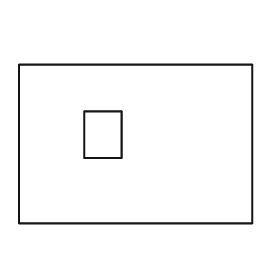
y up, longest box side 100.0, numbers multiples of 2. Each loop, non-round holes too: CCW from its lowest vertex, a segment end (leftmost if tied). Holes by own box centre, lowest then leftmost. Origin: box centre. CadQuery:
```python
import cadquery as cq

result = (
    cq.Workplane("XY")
    .moveTo(-50.0, -34.0)
    .lineTo(50.0, -34.0)
    .lineTo(50.0, 34.0)
    .lineTo(-50.0, 34.0)
    .close()
    .moveTo(-22.0, -6.0)
    .lineTo(-6.0, -6.0)
    .lineTo(-6.0, 14.0)
    .lineTo(-22.0, 14.0)
    .close()
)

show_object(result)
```